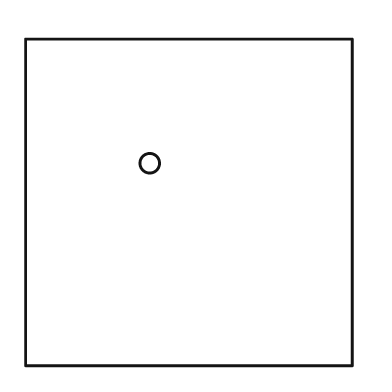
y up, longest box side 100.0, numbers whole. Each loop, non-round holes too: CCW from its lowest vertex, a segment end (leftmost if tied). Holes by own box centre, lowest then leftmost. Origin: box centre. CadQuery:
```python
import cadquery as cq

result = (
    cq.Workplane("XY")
    .moveTo(-50.0, -50.0)
    .lineTo(50.0, -50.0)
    .lineTo(50.0, 50.0)
    .lineTo(-50.0, 50.0)
    .close()
    .moveTo(-12.0, 12.0)
    .circle(3.0)
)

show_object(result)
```